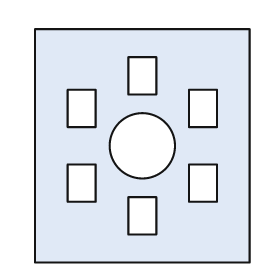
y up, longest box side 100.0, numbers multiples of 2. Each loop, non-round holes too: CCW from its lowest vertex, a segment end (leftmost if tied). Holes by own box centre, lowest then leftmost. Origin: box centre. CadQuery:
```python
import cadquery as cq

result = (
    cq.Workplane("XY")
    .moveTo(-46.0, -50.0)
    .lineTo(46.0, -50.0)
    .lineTo(46.0, 50.0)
    .lineTo(-46.0, 50.0)
    .close()
    .moveTo(-6.0, -38.0)
    .lineTo(6.0, -38.0)
    .lineTo(6.0, -22.0)
    .lineTo(-6.0, -22.0)
    .close()
    .moveTo(-32.0, -24.0)
    .lineTo(-20.0, -24.0)
    .lineTo(-20.0, -8.0)
    .lineTo(-32.0, -8.0)
    .close()
    .moveTo(20.0, -24.0)
    .lineTo(32.0, -24.0)
    .lineTo(32.0, -8.0)
    .lineTo(20.0, -8.0)
    .close()
    .moveTo(0.0, 0.0)
    .circle(14.0)
    .moveTo(-32.0, 8.0)
    .lineTo(-20.0, 8.0)
    .lineTo(-20.0, 24.0)
    .lineTo(-32.0, 24.0)
    .close()
    .moveTo(20.0, 8.0)
    .lineTo(32.0, 8.0)
    .lineTo(32.0, 24.0)
    .lineTo(20.0, 24.0)
    .close()
    .moveTo(-6.0, 22.0)
    .lineTo(6.0, 22.0)
    .lineTo(6.0, 38.0)
    .lineTo(-6.0, 38.0)
    .close()
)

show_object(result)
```